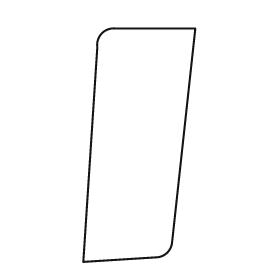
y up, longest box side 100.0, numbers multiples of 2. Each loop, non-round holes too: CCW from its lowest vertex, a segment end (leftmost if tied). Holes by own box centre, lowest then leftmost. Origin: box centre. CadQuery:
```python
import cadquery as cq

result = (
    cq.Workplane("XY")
    .moveTo(-24.0, -50.0)
    .lineTo(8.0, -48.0)
    .threePointArc((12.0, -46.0), (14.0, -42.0))
    .lineTo(24.0, 50.0)
    .lineTo(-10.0, 50.0)
    .threePointArc((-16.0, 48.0), (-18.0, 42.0))
    .close()
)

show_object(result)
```